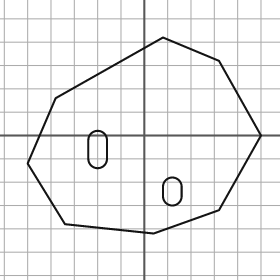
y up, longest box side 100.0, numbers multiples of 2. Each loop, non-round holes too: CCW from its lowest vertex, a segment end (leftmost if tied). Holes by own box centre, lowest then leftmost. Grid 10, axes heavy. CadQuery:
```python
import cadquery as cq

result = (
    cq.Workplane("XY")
    .moveTo(4.0, -42.0)
    .lineTo(32.0, -32.0)
    .lineTo(50.0, 0.0)
    .lineTo(32.0, 32.0)
    .lineTo(8.0, 42.0)
    .lineTo(-38.0, 16.0)
    .lineTo(-50.0, -12.0)
    .lineTo(-34.0, -38.0)
    .close()
    .moveTo(8.0, -26.0)
    .threePointArc((12.0, -30.0), (16.0, -26.0))
    .lineTo(16.0, -22.0)
    .threePointArc((12.0, -18.0), (8.0, -22.0))
    .close()
    .moveTo(-24.0, -10.0)
    .threePointArc((-20.0, -14.0), (-16.0, -10.0))
    .lineTo(-16.0, -2.0)
    .threePointArc((-20.0, 2.0), (-24.0, -2.0))
    .close()
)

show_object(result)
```